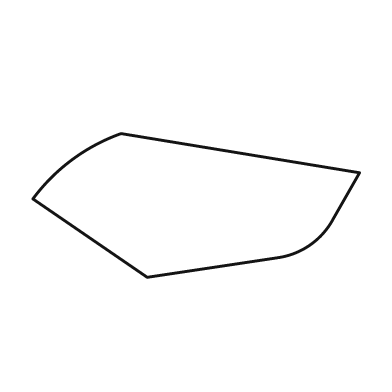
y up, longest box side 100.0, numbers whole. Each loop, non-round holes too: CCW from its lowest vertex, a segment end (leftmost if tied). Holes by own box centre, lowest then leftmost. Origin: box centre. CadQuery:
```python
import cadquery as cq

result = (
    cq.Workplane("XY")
    .moveTo(-15.0, -22.0)
    .lineTo(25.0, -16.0)
    .threePointArc((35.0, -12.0), (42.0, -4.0))
    .lineTo(50.0, 10.0)
    .lineTo(-23.0, 22.0)
    .threePointArc((-38.0, 14.0), (-50.0, 2.0))
    .close()
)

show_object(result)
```